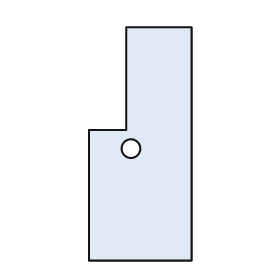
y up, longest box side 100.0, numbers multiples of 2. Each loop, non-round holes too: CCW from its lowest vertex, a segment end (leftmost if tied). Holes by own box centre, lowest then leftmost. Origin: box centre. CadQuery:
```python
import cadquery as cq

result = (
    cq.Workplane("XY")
    .moveTo(-22.0, -50.0)
    .lineTo(22.0, -50.0)
    .lineTo(22.0, 50.0)
    .lineTo(-6.0, 50.0)
    .lineTo(-6.0, 6.0)
    .lineTo(-22.0, 6.0)
    .close()
    .moveTo(-4.0, -2.0)
    .circle(4.0)
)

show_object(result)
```